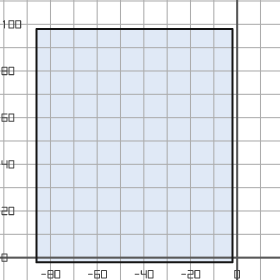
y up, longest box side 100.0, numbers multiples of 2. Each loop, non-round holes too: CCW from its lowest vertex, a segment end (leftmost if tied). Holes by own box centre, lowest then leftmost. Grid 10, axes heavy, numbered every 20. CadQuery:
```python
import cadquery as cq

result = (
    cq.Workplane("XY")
    .moveTo(-86.0, -2.0)
    .lineTo(-2.0, -2.0)
    .lineTo(-2.0, 98.0)
    .lineTo(-86.0, 98.0)
    .close()
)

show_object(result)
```